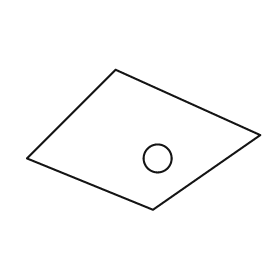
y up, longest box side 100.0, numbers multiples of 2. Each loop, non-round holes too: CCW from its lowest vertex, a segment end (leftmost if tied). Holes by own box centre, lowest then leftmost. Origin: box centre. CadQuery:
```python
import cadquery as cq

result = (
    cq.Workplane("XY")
    .moveTo(4.0, -30.0)
    .lineTo(50.0, 2.0)
    .lineTo(-12.0, 30.0)
    .lineTo(-50.0, -8.0)
    .close()
    .moveTo(6.0, -8.0)
    .circle(6.0)
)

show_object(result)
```